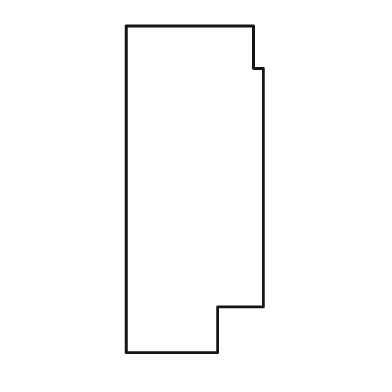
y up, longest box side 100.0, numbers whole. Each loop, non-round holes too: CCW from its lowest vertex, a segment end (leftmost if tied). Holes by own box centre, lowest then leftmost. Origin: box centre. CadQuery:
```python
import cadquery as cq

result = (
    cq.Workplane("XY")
    .moveTo(-21.0, -50.0)
    .lineTo(7.0, -50.0)
    .lineTo(7.0, -36.0)
    .lineTo(21.0, -36.0)
    .lineTo(21.0, 37.0)
    .lineTo(18.0, 37.0)
    .lineTo(18.0, 50.0)
    .lineTo(-21.0, 50.0)
    .close()
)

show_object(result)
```